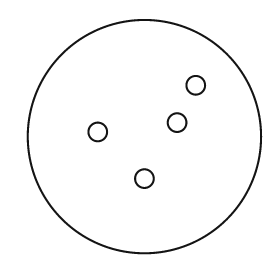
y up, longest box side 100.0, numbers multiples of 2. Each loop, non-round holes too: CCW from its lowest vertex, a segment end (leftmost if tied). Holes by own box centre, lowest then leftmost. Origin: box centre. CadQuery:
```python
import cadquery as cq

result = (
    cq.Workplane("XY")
    .moveTo(0.0, 0.0)
    .circle(50.0)
    .moveTo(0.0, -18.0)
    .circle(4.0)
    .moveTo(-20.0, 2.0)
    .circle(4.0)
    .moveTo(14.0, 6.0)
    .circle(4.0)
    .moveTo(22.0, 22.0)
    .circle(4.0)
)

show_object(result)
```